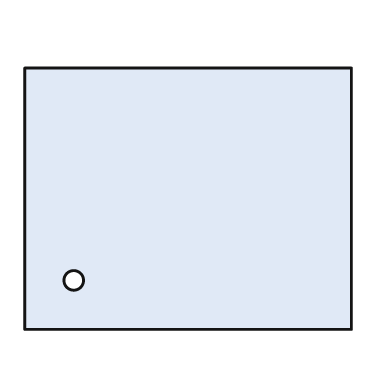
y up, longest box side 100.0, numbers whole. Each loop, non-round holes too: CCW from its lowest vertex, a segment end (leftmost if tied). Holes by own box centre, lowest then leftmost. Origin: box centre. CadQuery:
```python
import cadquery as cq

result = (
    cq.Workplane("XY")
    .moveTo(-50.0, -40.0)
    .lineTo(50.0, -40.0)
    .lineTo(50.0, 40.0)
    .lineTo(-50.0, 40.0)
    .close()
    .moveTo(-35.0, -25.0)
    .circle(3.0)
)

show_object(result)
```